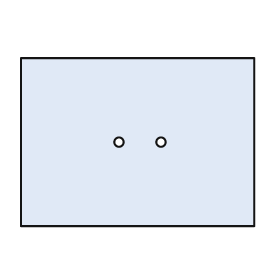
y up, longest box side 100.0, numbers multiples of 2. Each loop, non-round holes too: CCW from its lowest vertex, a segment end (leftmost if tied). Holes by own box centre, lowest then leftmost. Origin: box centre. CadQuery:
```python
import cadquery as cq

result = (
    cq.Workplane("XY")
    .moveTo(-50.0, -36.0)
    .lineTo(50.0, -36.0)
    .lineTo(50.0, 36.0)
    .lineTo(-50.0, 36.0)
    .close()
    .moveTo(-8.0, 0.0)
    .circle(2.0)
    .moveTo(10.0, 0.0)
    .circle(2.0)
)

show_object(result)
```